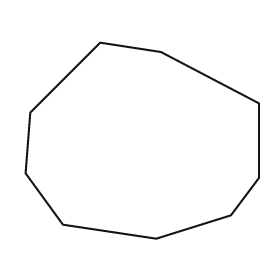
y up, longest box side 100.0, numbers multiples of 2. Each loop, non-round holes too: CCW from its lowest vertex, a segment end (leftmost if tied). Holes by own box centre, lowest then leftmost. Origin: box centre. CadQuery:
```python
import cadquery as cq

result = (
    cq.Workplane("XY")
    .moveTo(6.0, -42.0)
    .lineTo(38.0, -32.0)
    .lineTo(50.0, -16.0)
    .lineTo(50.0, 16.0)
    .lineTo(8.0, 38.0)
    .lineTo(-18.0, 42.0)
    .lineTo(-48.0, 12.0)
    .lineTo(-50.0, -14.0)
    .lineTo(-34.0, -36.0)
    .close()
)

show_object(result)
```